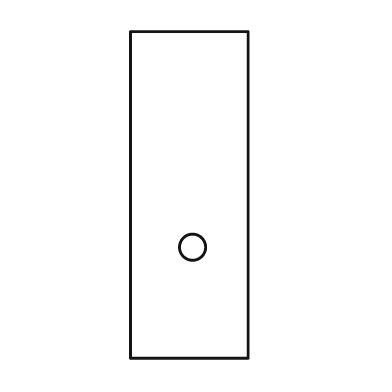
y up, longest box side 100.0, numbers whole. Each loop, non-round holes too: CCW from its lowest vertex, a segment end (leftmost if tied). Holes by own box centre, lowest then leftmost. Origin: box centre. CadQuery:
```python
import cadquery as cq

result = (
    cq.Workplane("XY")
    .moveTo(-18.0, -50.0)
    .lineTo(18.0, -50.0)
    .lineTo(18.0, 50.0)
    .lineTo(-18.0, 50.0)
    .close()
    .moveTo(1.0, -16.0)
    .circle(4.0)
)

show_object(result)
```